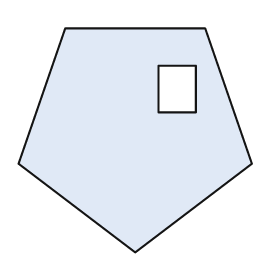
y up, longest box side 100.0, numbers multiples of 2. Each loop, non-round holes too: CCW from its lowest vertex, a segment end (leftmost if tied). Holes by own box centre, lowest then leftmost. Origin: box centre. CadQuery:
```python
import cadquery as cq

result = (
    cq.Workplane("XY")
    .moveTo(0.0, -48.0)
    .lineTo(50.0, -10.0)
    .lineTo(30.0, 48.0)
    .lineTo(-30.0, 48.0)
    .lineTo(-50.0, -10.0)
    .close()
    .moveTo(10.0, 12.0)
    .lineTo(26.0, 12.0)
    .lineTo(26.0, 32.0)
    .lineTo(10.0, 32.0)
    .close()
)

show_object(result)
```